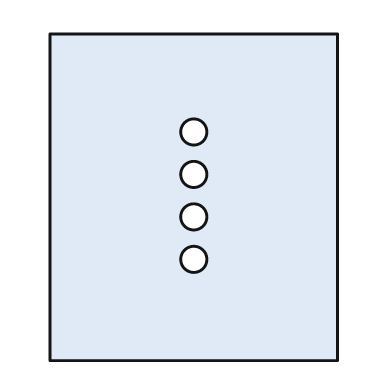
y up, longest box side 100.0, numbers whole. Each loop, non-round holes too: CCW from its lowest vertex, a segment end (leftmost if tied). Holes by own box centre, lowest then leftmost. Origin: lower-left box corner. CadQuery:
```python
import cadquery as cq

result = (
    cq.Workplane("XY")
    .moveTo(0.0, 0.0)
    .lineTo(88.0, 0.0)
    .lineTo(88.0, 100.0)
    .lineTo(0.0, 100.0)
    .close()
    .moveTo(44.0, 31.0)
    .circle(4.0)
    .moveTo(44.0, 44.0)
    .circle(4.0)
    .moveTo(44.0, 57.0)
    .circle(4.0)
    .moveTo(44.0, 70.0)
    .circle(4.0)
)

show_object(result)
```